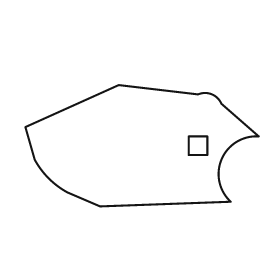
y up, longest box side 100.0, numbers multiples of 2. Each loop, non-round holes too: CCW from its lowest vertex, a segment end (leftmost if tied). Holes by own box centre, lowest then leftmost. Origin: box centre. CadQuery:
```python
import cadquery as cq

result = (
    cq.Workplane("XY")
    .moveTo(-18.0, -26.0)
    .lineTo(38.0, -24.0)
    .threePointArc((34.0, -6.0), (50.0, 4.0))
    .lineTo(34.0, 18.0)
    .threePointArc((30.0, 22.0), (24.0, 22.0))
    .lineTo(-10.0, 26.0)
    .lineTo(-50.0, 8.0)
    .lineTo(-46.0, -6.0)
    .threePointArc((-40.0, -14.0), (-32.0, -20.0))
    .close()
    .moveTo(20.0, -4.0)
    .lineTo(28.0, -4.0)
    .lineTo(28.0, 4.0)
    .lineTo(20.0, 4.0)
    .close()
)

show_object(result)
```